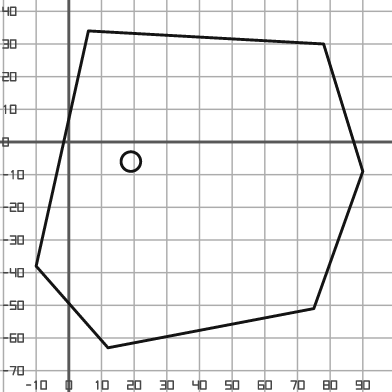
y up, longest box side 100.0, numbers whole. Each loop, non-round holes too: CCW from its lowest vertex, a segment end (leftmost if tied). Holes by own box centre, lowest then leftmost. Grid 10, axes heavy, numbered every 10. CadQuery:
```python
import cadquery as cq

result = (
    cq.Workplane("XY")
    .moveTo(12.0, -63.0)
    .lineTo(75.0, -51.0)
    .lineTo(90.0, -9.0)
    .lineTo(78.0, 30.0)
    .lineTo(6.0, 34.0)
    .lineTo(-10.0, -38.0)
    .close()
    .moveTo(19.0, -6.0)
    .circle(3.0)
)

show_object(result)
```